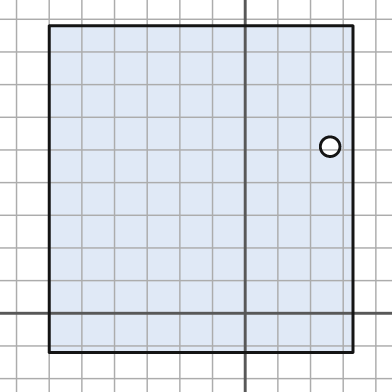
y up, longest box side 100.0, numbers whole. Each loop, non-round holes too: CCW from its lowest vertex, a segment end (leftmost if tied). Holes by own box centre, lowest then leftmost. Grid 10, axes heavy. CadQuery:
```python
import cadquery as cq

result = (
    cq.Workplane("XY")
    .moveTo(-60.0, -12.0)
    .lineTo(33.0, -12.0)
    .lineTo(33.0, 88.0)
    .lineTo(-60.0, 88.0)
    .close()
    .moveTo(26.0, 51.0)
    .circle(3.0)
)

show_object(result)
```